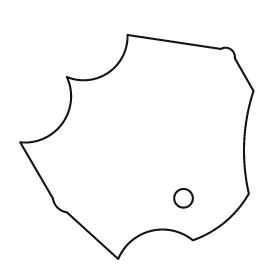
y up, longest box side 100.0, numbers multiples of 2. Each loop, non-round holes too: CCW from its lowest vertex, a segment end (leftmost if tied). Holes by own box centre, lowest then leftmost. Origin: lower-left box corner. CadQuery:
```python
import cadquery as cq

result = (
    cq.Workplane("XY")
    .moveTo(42.0, 0.0)
    .threePointArc((56.0, 12.0), (74.0, 8.0))
    .threePointArc((88.0, 16.0), (98.0, 28.0))
    .threePointArc((96.0, 50.0), (100.0, 72.0))
    .lineTo(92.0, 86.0)
    .threePointArc((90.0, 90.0), (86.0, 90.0))
    .lineTo(46.0, 96.0)
    .threePointArc((38.0, 80.0), (20.0, 78.0))
    .threePointArc((18.0, 58.0), (0.0, 50.0))
    .lineTo(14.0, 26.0)
    .threePointArc((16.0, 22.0), (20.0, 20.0))
    .close()
    .moveTo(70.0, 26.0)
    .circle(4.0)
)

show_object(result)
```